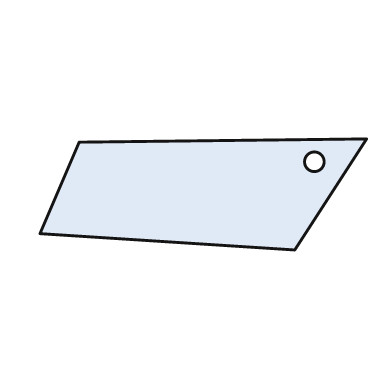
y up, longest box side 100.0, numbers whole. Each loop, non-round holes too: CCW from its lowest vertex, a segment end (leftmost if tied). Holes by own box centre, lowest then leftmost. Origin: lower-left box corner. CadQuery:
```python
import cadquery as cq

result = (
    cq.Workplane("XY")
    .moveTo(78.0, 0.0)
    .lineTo(100.0, 34.0)
    .lineTo(12.0, 33.0)
    .lineTo(0.0, 5.0)
    .close()
    .moveTo(84.0, 27.0)
    .circle(3.0)
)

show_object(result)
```